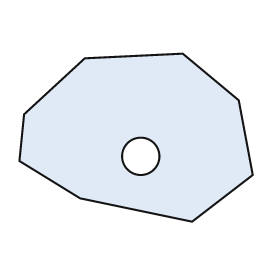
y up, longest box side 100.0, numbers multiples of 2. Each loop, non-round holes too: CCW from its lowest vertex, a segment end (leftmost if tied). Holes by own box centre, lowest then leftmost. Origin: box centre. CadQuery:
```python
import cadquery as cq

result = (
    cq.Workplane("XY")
    .moveTo(24.0, -36.0)
    .lineTo(50.0, -16.0)
    .lineTo(44.0, 16.0)
    .lineTo(20.0, 36.0)
    .lineTo(-22.0, 34.0)
    .lineTo(-48.0, 10.0)
    .lineTo(-50.0, -10.0)
    .lineTo(-24.0, -26.0)
    .close()
    .moveTo(2.0, -8.0)
    .circle(8.0)
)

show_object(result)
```